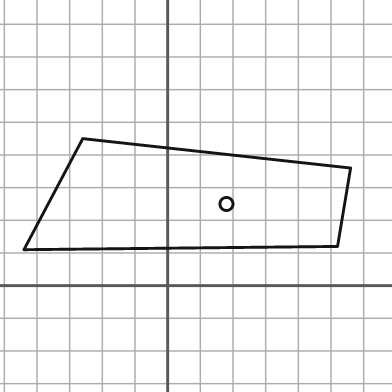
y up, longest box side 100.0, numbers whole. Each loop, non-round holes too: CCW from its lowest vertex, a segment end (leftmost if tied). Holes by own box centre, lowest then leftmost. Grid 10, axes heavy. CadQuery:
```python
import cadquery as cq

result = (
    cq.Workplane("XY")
    .moveTo(-44.0, 11.0)
    .lineTo(52.0, 12.0)
    .lineTo(56.0, 36.0)
    .lineTo(-26.0, 45.0)
    .close()
    .moveTo(18.0, 25.0)
    .circle(2.0)
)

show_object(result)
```